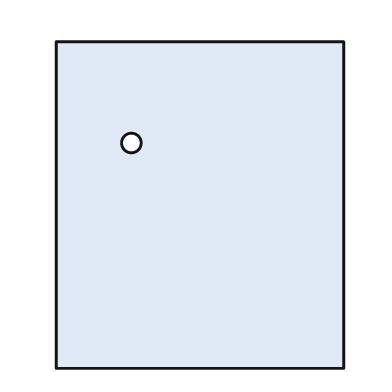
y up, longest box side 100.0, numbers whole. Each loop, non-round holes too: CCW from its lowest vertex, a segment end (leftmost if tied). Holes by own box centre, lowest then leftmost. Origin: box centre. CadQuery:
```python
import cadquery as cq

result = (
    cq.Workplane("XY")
    .moveTo(-44.0, -50.0)
    .lineTo(44.0, -50.0)
    .lineTo(44.0, 50.0)
    .lineTo(-44.0, 50.0)
    .close()
    .moveTo(-21.0, 19.0)
    .circle(3.0)
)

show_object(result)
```